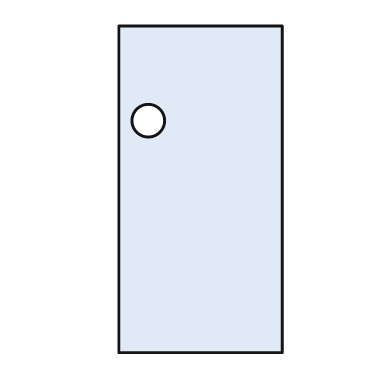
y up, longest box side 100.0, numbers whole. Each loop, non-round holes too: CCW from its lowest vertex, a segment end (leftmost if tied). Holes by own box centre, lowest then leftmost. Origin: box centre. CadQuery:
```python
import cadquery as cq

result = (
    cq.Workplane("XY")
    .moveTo(-25.0, -50.0)
    .lineTo(25.0, -50.0)
    .lineTo(25.0, 50.0)
    .lineTo(-25.0, 50.0)
    .close()
    .moveTo(-16.0, 21.0)
    .circle(5.0)
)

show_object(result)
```